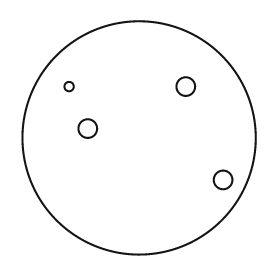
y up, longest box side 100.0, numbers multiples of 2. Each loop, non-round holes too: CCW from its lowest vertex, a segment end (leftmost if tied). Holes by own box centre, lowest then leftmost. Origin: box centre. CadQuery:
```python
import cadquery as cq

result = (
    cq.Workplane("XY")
    .moveTo(0.0, 0.0)
    .circle(50.0)
    .moveTo(36.0, -18.0)
    .circle(4.0)
    .moveTo(-22.0, 4.0)
    .circle(4.0)
    .moveTo(-30.0, 22.0)
    .circle(2.0)
    .moveTo(20.0, 22.0)
    .circle(4.0)
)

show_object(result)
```